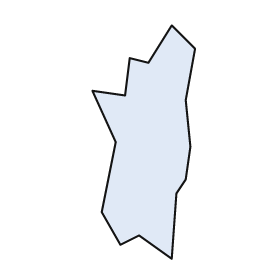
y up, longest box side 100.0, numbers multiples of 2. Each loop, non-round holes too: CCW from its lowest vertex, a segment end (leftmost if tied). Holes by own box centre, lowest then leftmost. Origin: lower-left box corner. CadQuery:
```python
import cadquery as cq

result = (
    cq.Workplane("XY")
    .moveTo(34.0, 0.0)
    .lineTo(36.0, 28.0)
    .lineTo(40.0, 34.0)
    .lineTo(42.0, 48.0)
    .lineTo(40.0, 68.0)
    .lineTo(44.0, 90.0)
    .lineTo(34.0, 100.0)
    .lineTo(24.0, 84.0)
    .lineTo(16.0, 86.0)
    .lineTo(14.0, 70.0)
    .lineTo(0.0, 72.0)
    .lineTo(10.0, 50.0)
    .lineTo(4.0, 20.0)
    .lineTo(12.0, 6.0)
    .lineTo(20.0, 10.0)
    .close()
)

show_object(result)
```